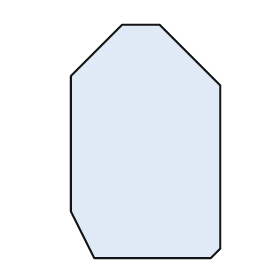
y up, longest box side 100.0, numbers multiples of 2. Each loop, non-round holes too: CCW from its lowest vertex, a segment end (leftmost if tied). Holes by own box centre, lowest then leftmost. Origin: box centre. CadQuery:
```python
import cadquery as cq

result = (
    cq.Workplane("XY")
    .moveTo(-22.0, -50.0)
    .lineTo(28.0, -50.0)
    .lineTo(32.0, -46.0)
    .lineTo(32.0, 24.0)
    .lineTo(6.0, 50.0)
    .lineTo(-10.0, 50.0)
    .lineTo(-32.0, 28.0)
    .lineTo(-32.0, -30.0)
    .close()
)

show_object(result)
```